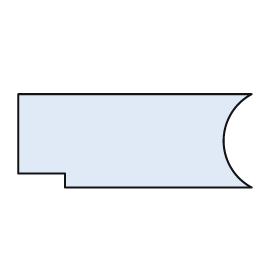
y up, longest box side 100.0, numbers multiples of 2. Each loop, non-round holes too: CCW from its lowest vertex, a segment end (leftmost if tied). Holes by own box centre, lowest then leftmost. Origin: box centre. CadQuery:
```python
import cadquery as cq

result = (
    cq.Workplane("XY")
    .moveTo(-30.0, -20.0)
    .lineTo(50.0, -20.0)
    .threePointArc((38.0, 0.0), (50.0, 20.0))
    .lineTo(-50.0, 20.0)
    .lineTo(-50.0, -14.0)
    .lineTo(-30.0, -14.0)
    .close()
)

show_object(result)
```